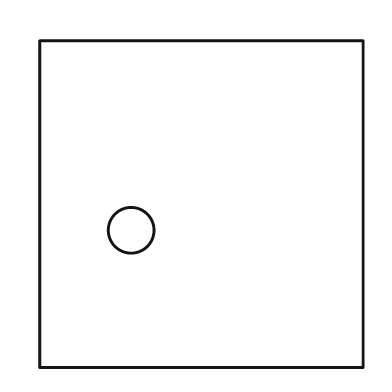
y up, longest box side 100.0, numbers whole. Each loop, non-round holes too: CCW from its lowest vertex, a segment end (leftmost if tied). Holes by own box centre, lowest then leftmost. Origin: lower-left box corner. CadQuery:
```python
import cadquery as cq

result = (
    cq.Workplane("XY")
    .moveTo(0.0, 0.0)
    .lineTo(99.0, 0.0)
    .lineTo(99.0, 100.0)
    .lineTo(0.0, 100.0)
    .close()
    .moveTo(28.0, 42.0)
    .circle(7.0)
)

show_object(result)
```